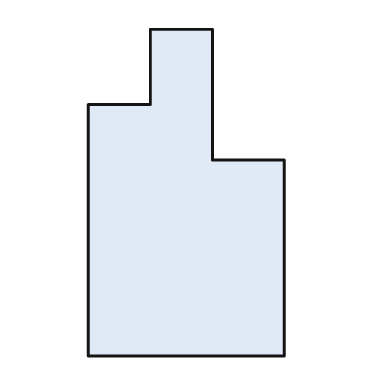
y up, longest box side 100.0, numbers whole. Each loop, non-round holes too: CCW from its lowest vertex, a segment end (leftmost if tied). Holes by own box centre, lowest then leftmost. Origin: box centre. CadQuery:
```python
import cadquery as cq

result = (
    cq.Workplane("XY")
    .moveTo(-30.0, -50.0)
    .lineTo(30.0, -50.0)
    .lineTo(30.0, 10.0)
    .lineTo(8.0, 10.0)
    .lineTo(8.0, 50.0)
    .lineTo(-11.0, 50.0)
    .lineTo(-11.0, 27.0)
    .lineTo(-30.0, 27.0)
    .close()
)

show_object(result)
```